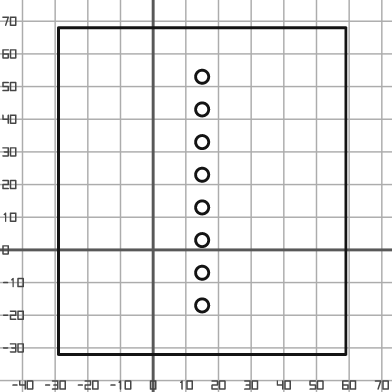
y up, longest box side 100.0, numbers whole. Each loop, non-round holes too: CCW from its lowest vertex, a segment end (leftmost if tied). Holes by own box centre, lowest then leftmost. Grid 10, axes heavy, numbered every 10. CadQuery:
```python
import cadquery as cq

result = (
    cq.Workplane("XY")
    .moveTo(-29.0, -32.0)
    .lineTo(59.0, -32.0)
    .lineTo(59.0, 68.0)
    .lineTo(-29.0, 68.0)
    .close()
    .moveTo(15.0, -17.0)
    .circle(2.0)
    .moveTo(15.0, -7.0)
    .circle(2.0)
    .moveTo(15.0, 3.0)
    .circle(2.0)
    .moveTo(15.0, 13.0)
    .circle(2.0)
    .moveTo(15.0, 23.0)
    .circle(2.0)
    .moveTo(15.0, 33.0)
    .circle(2.0)
    .moveTo(15.0, 43.0)
    .circle(2.0)
    .moveTo(15.0, 53.0)
    .circle(2.0)
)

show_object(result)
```